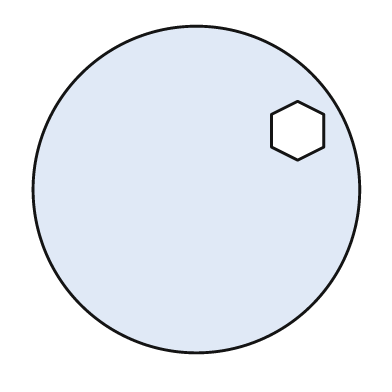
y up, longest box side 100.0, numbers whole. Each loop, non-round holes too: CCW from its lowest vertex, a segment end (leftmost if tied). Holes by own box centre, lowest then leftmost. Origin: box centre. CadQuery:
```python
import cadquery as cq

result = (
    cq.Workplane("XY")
    .moveTo(0.0, 0.0)
    .circle(50.0)
    .moveTo(31.0, 9.0)
    .lineTo(39.0, 13.0)
    .lineTo(39.0, 23.0)
    .lineTo(31.0, 27.0)
    .lineTo(23.0, 23.0)
    .lineTo(23.0, 13.0)
    .close()
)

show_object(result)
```